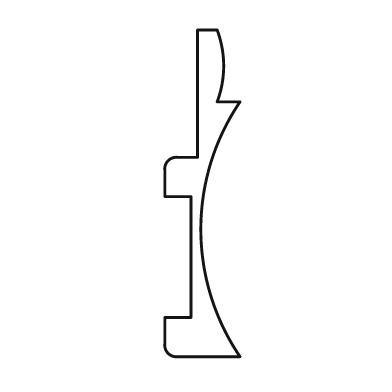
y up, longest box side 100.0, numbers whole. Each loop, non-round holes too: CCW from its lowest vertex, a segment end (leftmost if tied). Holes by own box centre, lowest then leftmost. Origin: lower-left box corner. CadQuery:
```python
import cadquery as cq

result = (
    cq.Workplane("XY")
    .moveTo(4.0, 0.0)
    .lineTo(23.0, 0.0)
    .threePointArc((11.0, 39.0), (23.0, 78.0))
    .lineTo(16.0, 78.0)
    .threePointArc((18.0, 89.0), (16.0, 100.0))
    .lineTo(10.0, 100.0)
    .lineTo(10.0, 61.0)
    .lineTo(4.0, 61.0)
    .threePointArc((1.0, 60.0), (0.0, 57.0))
    .lineTo(0.0, 49.0)
    .lineTo(8.0, 49.0)
    .lineTo(8.0, 12.0)
    .lineTo(0.0, 12.0)
    .lineTo(0.0, 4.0)
    .threePointArc((1.0, 1.0), (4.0, 0.0))
    .close()
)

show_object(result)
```